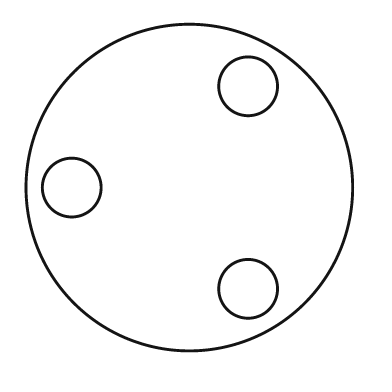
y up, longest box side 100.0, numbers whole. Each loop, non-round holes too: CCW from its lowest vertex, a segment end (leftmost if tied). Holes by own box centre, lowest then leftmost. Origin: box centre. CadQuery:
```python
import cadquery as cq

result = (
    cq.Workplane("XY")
    .moveTo(0.0, 0.0)
    .circle(50.0)
    .moveTo(18.0, -31.0)
    .circle(9.0)
    .moveTo(-36.0, 0.0)
    .circle(9.0)
    .moveTo(18.0, 31.0)
    .circle(9.0)
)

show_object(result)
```